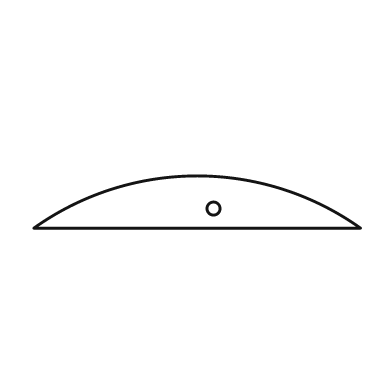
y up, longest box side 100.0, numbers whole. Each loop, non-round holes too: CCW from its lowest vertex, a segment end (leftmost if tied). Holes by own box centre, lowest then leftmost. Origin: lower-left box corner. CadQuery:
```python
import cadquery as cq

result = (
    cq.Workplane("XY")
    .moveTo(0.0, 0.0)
    .lineTo(100.0, 0.0)
    .threePointArc((50.0, 16.0), (0.0, 0.0))
    .close()
    .moveTo(55.0, 6.0)
    .circle(2.0)
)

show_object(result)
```